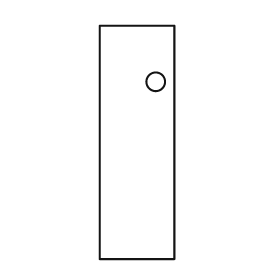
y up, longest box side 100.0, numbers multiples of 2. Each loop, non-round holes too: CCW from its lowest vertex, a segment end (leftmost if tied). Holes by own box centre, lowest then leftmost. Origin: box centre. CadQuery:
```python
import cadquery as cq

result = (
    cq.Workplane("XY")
    .moveTo(-16.0, -50.0)
    .lineTo(16.0, -50.0)
    .lineTo(16.0, 50.0)
    .lineTo(-16.0, 50.0)
    .close()
    .moveTo(8.0, 26.0)
    .circle(4.0)
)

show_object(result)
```